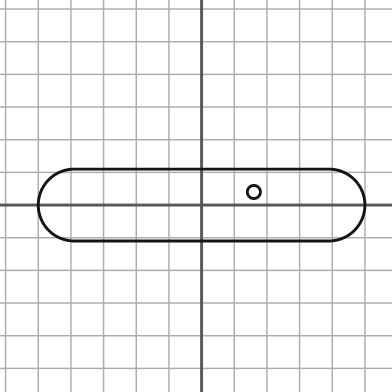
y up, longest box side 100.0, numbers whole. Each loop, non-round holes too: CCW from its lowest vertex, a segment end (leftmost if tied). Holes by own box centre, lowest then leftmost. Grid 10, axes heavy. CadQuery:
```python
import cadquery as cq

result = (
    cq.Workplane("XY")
    .moveTo(-39.0, -11.0)
    .lineTo(39.0, -11.0)
    .threePointArc((50.0, 0.0), (39.0, 11.0))
    .lineTo(-39.0, 11.0)
    .threePointArc((-50.0, 0.0), (-39.0, -11.0))
    .close()
    .moveTo(16.0, 4.0)
    .circle(2.0)
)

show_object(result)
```